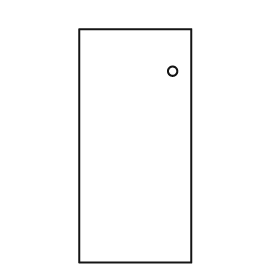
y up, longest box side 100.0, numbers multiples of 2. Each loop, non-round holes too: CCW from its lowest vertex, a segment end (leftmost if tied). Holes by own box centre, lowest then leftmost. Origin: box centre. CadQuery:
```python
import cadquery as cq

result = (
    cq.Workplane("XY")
    .moveTo(-24.0, -50.0)
    .lineTo(24.0, -50.0)
    .lineTo(24.0, 50.0)
    .lineTo(-24.0, 50.0)
    .close()
    .moveTo(16.0, 32.0)
    .circle(2.0)
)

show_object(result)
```